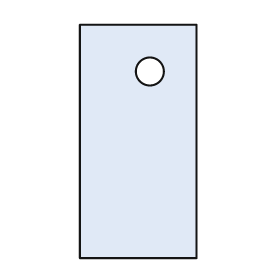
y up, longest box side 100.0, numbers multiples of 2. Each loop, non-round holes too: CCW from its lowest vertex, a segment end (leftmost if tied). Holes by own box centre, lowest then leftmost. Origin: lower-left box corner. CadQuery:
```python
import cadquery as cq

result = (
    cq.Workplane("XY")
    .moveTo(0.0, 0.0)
    .lineTo(50.0, 0.0)
    .lineTo(50.0, 100.0)
    .lineTo(0.0, 100.0)
    .close()
    .moveTo(30.0, 80.0)
    .circle(6.0)
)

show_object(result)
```